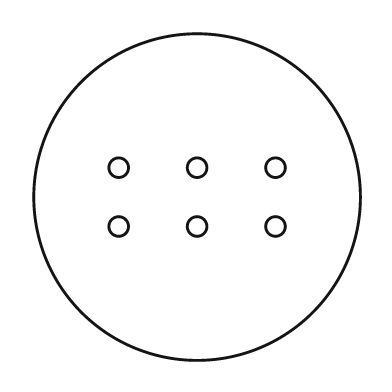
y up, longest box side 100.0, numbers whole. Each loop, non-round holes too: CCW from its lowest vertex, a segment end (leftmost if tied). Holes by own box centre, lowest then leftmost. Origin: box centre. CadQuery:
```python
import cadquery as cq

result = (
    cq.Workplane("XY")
    .moveTo(0.0, 0.0)
    .circle(50.0)
    .moveTo(-24.0, -9.0)
    .circle(3.0)
    .moveTo(0.0, -9.0)
    .circle(3.0)
    .moveTo(24.0, -9.0)
    .circle(3.0)
    .moveTo(-24.0, 9.0)
    .circle(3.0)
    .moveTo(0.0, 9.0)
    .circle(3.0)
    .moveTo(24.0, 9.0)
    .circle(3.0)
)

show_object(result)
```